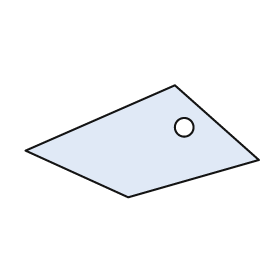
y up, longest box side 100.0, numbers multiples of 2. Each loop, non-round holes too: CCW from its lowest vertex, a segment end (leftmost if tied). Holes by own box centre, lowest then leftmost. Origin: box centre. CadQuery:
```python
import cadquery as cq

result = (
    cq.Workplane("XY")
    .moveTo(-6.0, -24.0)
    .lineTo(50.0, -8.0)
    .lineTo(14.0, 24.0)
    .lineTo(-50.0, -4.0)
    .close()
    .moveTo(18.0, 6.0)
    .circle(4.0)
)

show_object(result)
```